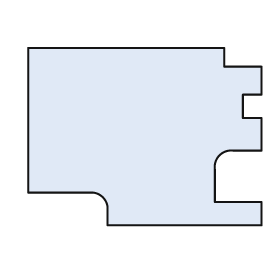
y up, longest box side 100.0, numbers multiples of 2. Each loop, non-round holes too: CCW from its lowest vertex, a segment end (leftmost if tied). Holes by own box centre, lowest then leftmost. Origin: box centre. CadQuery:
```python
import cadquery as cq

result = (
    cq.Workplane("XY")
    .moveTo(-16.0, -38.0)
    .lineTo(50.0, -38.0)
    .lineTo(50.0, -28.0)
    .lineTo(30.0, -28.0)
    .lineTo(30.0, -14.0)
    .threePointArc((32.0, -8.0), (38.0, -6.0))
    .lineTo(50.0, -6.0)
    .lineTo(50.0, 8.0)
    .lineTo(42.0, 8.0)
    .lineTo(42.0, 18.0)
    .lineTo(50.0, 18.0)
    .lineTo(50.0, 30.0)
    .lineTo(34.0, 30.0)
    .lineTo(34.0, 38.0)
    .lineTo(-50.0, 38.0)
    .lineTo(-50.0, -24.0)
    .lineTo(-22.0, -24.0)
    .threePointArc((-18.0, -26.0), (-16.0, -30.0))
    .close()
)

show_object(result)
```